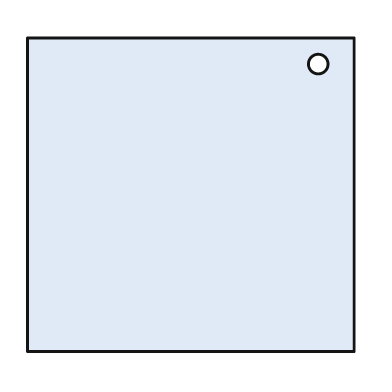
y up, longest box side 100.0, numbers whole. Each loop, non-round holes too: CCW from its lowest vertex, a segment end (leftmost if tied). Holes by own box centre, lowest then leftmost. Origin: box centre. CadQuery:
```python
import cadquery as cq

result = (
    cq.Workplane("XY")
    .moveTo(-50.0, -48.0)
    .lineTo(50.0, -48.0)
    .lineTo(50.0, 48.0)
    .lineTo(-50.0, 48.0)
    .close()
    .moveTo(39.0, 40.0)
    .circle(3.0)
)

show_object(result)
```